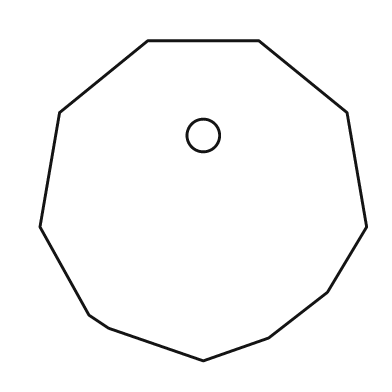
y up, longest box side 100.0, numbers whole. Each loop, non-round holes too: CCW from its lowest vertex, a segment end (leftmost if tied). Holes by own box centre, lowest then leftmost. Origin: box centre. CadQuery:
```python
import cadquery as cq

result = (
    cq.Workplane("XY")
    .moveTo(0.0, -49.0)
    .lineTo(20.0, -42.0)
    .lineTo(38.0, -28.0)
    .lineTo(50.0, -8.0)
    .lineTo(44.0, 27.0)
    .lineTo(17.0, 49.0)
    .lineTo(-17.0, 49.0)
    .lineTo(-44.0, 27.0)
    .lineTo(-50.0, -8.0)
    .lineTo(-35.0, -35.0)
    .lineTo(-29.0, -39.0)
    .close()
    .moveTo(0.0, 20.0)
    .circle(5.0)
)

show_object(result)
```